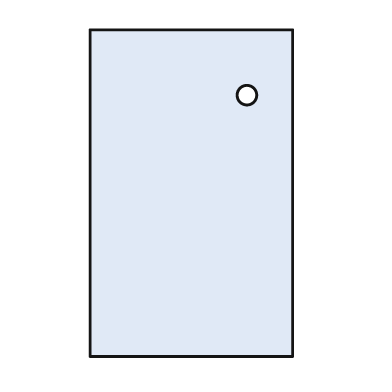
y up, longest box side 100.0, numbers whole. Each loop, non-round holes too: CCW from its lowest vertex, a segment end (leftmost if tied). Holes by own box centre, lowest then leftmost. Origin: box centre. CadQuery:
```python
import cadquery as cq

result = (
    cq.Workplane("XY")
    .moveTo(-31.0, -50.0)
    .lineTo(31.0, -50.0)
    .lineTo(31.0, 50.0)
    .lineTo(-31.0, 50.0)
    .close()
    .moveTo(17.0, 30.0)
    .circle(3.0)
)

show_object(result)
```